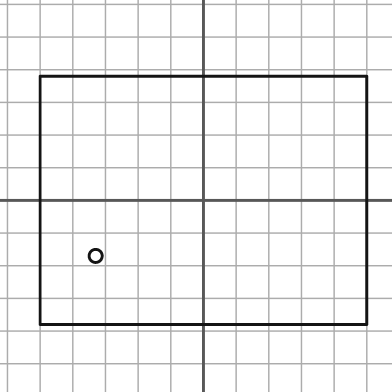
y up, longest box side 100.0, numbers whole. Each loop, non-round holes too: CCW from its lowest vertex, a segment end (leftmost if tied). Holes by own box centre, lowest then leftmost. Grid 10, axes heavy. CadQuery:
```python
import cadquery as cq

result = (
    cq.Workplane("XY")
    .moveTo(-50.0, -38.0)
    .lineTo(50.0, -38.0)
    .lineTo(50.0, 38.0)
    .lineTo(-50.0, 38.0)
    .close()
    .moveTo(-33.0, -17.0)
    .circle(2.0)
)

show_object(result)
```